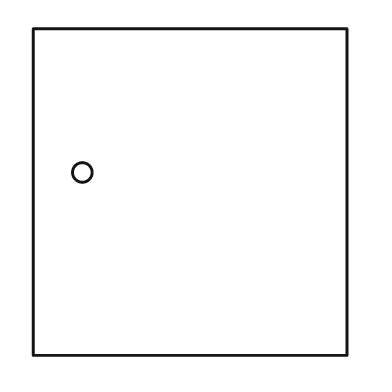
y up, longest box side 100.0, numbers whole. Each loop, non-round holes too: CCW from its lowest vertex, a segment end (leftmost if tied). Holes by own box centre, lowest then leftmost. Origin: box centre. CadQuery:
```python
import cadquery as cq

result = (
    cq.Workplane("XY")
    .moveTo(-48.0, -50.0)
    .lineTo(48.0, -50.0)
    .lineTo(48.0, 50.0)
    .lineTo(-48.0, 50.0)
    .close()
    .moveTo(-33.0, 6.0)
    .circle(3.0)
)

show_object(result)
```